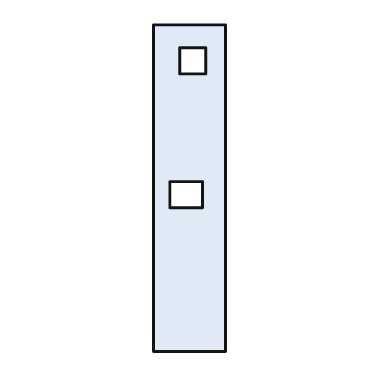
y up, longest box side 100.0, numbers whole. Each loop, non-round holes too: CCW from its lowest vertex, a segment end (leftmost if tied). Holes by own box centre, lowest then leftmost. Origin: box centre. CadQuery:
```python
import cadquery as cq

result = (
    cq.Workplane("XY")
    .moveTo(-11.0, -50.0)
    .lineTo(11.0, -50.0)
    .lineTo(11.0, 50.0)
    .lineTo(-11.0, 50.0)
    .close()
    .moveTo(-6.0, -6.0)
    .lineTo(4.0, -6.0)
    .lineTo(4.0, 2.0)
    .lineTo(-6.0, 2.0)
    .close()
    .moveTo(-3.0, 35.0)
    .lineTo(5.0, 35.0)
    .lineTo(5.0, 43.0)
    .lineTo(-3.0, 43.0)
    .close()
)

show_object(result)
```